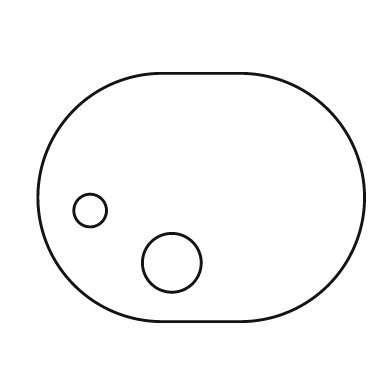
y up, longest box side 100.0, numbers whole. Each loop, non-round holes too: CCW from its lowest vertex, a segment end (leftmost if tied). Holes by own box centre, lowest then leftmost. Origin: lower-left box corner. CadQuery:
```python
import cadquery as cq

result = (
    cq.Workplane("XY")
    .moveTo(38.0, 0.0)
    .lineTo(62.0, 0.0)
    .threePointArc((100.0, 38.0), (62.0, 76.0))
    .lineTo(38.0, 76.0)
    .threePointArc((0.0, 38.0), (38.0, 0.0))
    .close()
    .moveTo(41.0, 18.0)
    .circle(9.0)
    .moveTo(16.0, 34.0)
    .circle(5.0)
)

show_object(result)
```